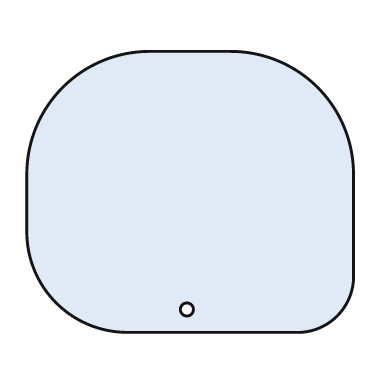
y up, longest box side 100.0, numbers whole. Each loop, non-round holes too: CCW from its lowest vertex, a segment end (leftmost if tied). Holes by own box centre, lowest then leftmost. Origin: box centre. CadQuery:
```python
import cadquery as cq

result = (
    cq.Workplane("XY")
    .moveTo(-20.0, -43.0)
    .lineTo(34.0, -43.0)
    .threePointArc((45.0, -38.0), (50.0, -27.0))
    .lineTo(50.0, 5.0)
    .threePointArc((39.0, 32.0), (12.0, 43.0))
    .lineTo(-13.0, 43.0)
    .threePointArc((-39.0, 32.0), (-50.0, 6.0))
    .lineTo(-50.0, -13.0)
    .threePointArc((-41.0, -34.0), (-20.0, -43.0))
    .close()
    .moveTo(-1.0, -36.0)
    .circle(2.0)
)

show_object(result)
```